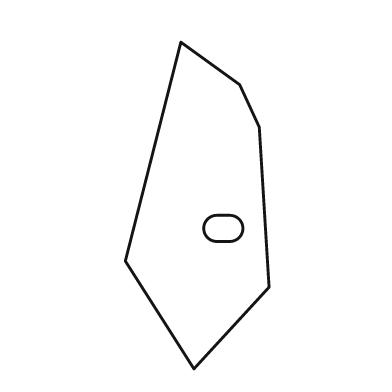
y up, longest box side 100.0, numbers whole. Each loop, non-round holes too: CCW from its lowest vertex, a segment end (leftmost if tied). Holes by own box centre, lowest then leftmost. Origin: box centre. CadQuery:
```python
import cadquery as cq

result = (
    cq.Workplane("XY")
    .moveTo(-1.0, -50.0)
    .lineTo(22.0, -25.0)
    .lineTo(19.0, 24.0)
    .lineTo(13.0, 37.0)
    .lineTo(-5.0, 50.0)
    .lineTo(-22.0, -17.0)
    .close()
    .moveTo(6.0, -11.0)
    .lineTo(10.0, -11.0)
    .threePointArc((14.0, -7.0), (10.0, -3.0))
    .lineTo(6.0, -3.0)
    .threePointArc((2.0, -7.0), (6.0, -11.0))
    .close()
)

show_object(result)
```